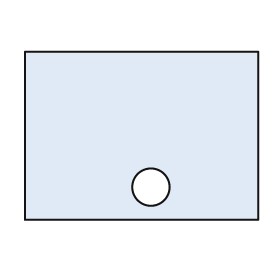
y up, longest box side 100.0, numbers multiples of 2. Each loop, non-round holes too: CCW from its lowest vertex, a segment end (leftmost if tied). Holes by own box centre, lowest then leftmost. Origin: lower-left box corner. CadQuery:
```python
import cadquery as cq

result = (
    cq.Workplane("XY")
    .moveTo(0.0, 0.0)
    .lineTo(100.0, 0.0)
    .lineTo(100.0, 72.0)
    .lineTo(0.0, 72.0)
    .close()
    .moveTo(54.0, 14.0)
    .circle(8.0)
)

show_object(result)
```